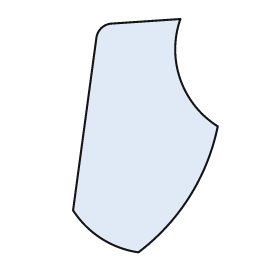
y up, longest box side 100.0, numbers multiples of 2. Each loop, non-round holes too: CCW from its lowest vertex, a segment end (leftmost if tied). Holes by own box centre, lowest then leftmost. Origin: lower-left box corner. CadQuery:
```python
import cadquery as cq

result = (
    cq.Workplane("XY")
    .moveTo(28.0, 0.0)
    .threePointArc((50.0, 24.0), (62.0, 54.0))
    .threePointArc((46.0, 74.0), (46.0, 100.0))
    .lineTo(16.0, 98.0)
    .threePointArc((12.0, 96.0), (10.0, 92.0))
    .lineTo(0.0, 18.0)
    .threePointArc((12.0, 6.0), (28.0, 0.0))
    .close()
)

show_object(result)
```